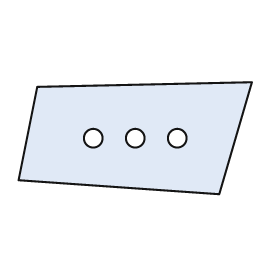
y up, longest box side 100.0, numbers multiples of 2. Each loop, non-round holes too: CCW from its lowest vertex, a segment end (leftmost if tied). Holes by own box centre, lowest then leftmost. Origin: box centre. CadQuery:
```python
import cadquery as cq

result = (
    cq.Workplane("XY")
    .moveTo(36.0, -24.0)
    .lineTo(50.0, 24.0)
    .lineTo(-42.0, 22.0)
    .lineTo(-50.0, -18.0)
    .close()
    .moveTo(-18.0, 0.0)
    .circle(4.0)
    .moveTo(0.0, 0.0)
    .circle(4.0)
    .moveTo(18.0, 0.0)
    .circle(4.0)
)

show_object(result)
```